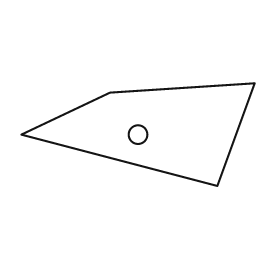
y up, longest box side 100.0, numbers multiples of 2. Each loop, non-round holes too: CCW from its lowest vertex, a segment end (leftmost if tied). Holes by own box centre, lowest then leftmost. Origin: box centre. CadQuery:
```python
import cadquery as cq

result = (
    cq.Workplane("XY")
    .moveTo(34.0, -22.0)
    .lineTo(50.0, 22.0)
    .lineTo(-12.0, 18.0)
    .lineTo(-50.0, 0.0)
    .close()
    .moveTo(0.0, 0.0)
    .circle(4.0)
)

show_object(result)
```